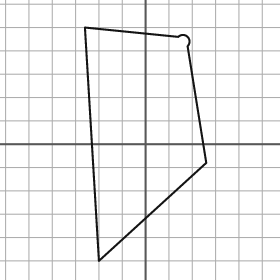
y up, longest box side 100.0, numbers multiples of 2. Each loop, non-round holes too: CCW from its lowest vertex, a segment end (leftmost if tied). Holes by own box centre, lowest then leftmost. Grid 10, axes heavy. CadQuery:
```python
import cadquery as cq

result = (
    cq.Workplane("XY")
    .moveTo(-20.0, -50.0)
    .lineTo(26.0, -8.0)
    .lineTo(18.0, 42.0)
    .threePointArc((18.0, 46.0), (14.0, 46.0))
    .lineTo(-26.0, 50.0)
    .close()
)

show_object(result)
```